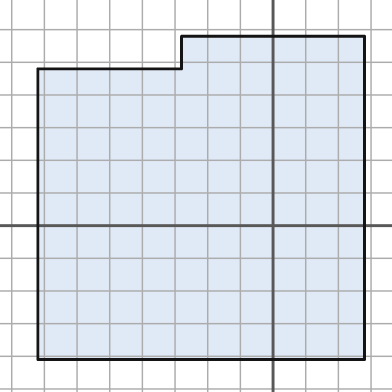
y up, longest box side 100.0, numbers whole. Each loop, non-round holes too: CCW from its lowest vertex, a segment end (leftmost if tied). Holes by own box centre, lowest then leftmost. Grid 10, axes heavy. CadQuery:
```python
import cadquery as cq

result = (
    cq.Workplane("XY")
    .moveTo(-72.0, -41.0)
    .lineTo(28.0, -41.0)
    .lineTo(28.0, 58.0)
    .lineTo(-28.0, 58.0)
    .lineTo(-28.0, 48.0)
    .lineTo(-72.0, 48.0)
    .close()
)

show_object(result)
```